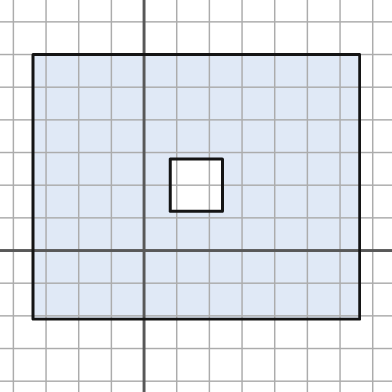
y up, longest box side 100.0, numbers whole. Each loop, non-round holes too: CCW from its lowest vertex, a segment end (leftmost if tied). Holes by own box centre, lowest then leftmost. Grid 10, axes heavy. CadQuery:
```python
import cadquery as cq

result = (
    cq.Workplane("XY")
    .moveTo(-34.0, -21.0)
    .lineTo(66.0, -21.0)
    .lineTo(66.0, 60.0)
    .lineTo(-34.0, 60.0)
    .close()
    .moveTo(8.0, 12.0)
    .lineTo(24.0, 12.0)
    .lineTo(24.0, 28.0)
    .lineTo(8.0, 28.0)
    .close()
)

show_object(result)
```